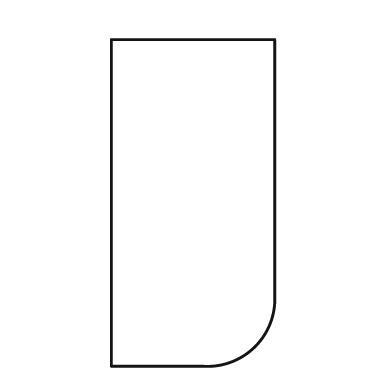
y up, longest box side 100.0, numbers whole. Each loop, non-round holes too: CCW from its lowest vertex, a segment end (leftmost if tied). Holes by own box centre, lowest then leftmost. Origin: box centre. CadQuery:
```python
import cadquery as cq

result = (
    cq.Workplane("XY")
    .moveTo(-25.0, -50.0)
    .lineTo(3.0, -50.0)
    .threePointArc((19.0, -44.0), (25.0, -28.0))
    .lineTo(25.0, 50.0)
    .lineTo(-25.0, 50.0)
    .close()
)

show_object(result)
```